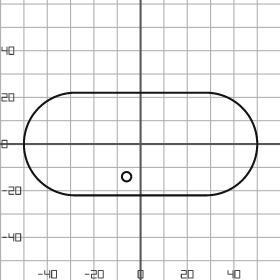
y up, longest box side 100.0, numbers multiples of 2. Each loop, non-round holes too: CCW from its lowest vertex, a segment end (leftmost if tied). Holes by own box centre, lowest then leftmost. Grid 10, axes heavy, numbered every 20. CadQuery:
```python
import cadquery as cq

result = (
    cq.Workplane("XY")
    .moveTo(-28.0, -22.0)
    .lineTo(28.0, -22.0)
    .threePointArc((50.0, 0.0), (28.0, 22.0))
    .lineTo(-28.0, 22.0)
    .threePointArc((-50.0, 0.0), (-28.0, -22.0))
    .close()
    .moveTo(-6.0, -14.0)
    .circle(2.0)
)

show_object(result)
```